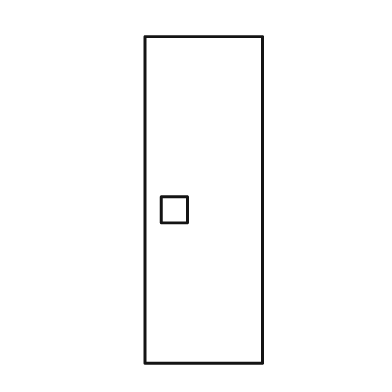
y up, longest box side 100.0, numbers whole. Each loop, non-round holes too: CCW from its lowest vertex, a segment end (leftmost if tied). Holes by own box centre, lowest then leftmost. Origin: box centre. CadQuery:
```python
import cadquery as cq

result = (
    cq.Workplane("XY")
    .moveTo(-18.0, -50.0)
    .lineTo(18.0, -50.0)
    .lineTo(18.0, 50.0)
    .lineTo(-18.0, 50.0)
    .close()
    .moveTo(-13.0, -7.0)
    .lineTo(-5.0, -7.0)
    .lineTo(-5.0, 1.0)
    .lineTo(-13.0, 1.0)
    .close()
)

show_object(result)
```